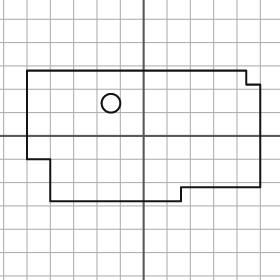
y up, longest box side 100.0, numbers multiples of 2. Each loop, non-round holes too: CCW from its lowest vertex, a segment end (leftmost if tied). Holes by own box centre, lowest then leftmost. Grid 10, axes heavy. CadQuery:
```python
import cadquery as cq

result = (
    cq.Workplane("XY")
    .moveTo(-40.0, -28.0)
    .lineTo(16.0, -28.0)
    .lineTo(16.0, -22.0)
    .lineTo(50.0, -22.0)
    .lineTo(50.0, 22.0)
    .lineTo(44.0, 22.0)
    .lineTo(44.0, 28.0)
    .lineTo(-50.0, 28.0)
    .lineTo(-50.0, -10.0)
    .lineTo(-40.0, -10.0)
    .close()
    .moveTo(-14.0, 14.0)
    .circle(4.0)
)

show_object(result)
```